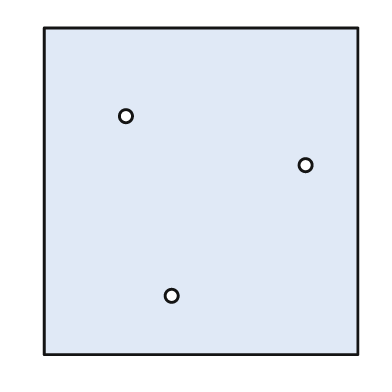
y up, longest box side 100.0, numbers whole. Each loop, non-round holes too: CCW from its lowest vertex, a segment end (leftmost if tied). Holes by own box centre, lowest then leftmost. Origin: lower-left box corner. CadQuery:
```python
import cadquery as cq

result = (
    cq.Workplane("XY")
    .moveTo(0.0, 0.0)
    .lineTo(96.0, 0.0)
    .lineTo(96.0, 100.0)
    .lineTo(0.0, 100.0)
    .close()
    .moveTo(39.0, 18.0)
    .circle(2.0)
    .moveTo(80.0, 58.0)
    .circle(2.0)
    .moveTo(25.0, 73.0)
    .circle(2.0)
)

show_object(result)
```